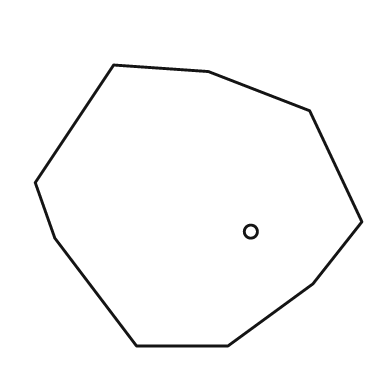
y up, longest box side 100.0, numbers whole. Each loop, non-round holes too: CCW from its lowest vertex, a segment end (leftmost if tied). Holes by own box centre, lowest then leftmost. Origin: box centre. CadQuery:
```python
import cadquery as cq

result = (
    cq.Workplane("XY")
    .moveTo(-19.0, -43.0)
    .lineTo(9.0, -43.0)
    .lineTo(35.0, -24.0)
    .lineTo(50.0, -5.0)
    .lineTo(34.0, 29.0)
    .lineTo(3.0, 41.0)
    .lineTo(-26.0, 43.0)
    .lineTo(-50.0, 7.0)
    .lineTo(-44.0, -10.0)
    .close()
    .moveTo(16.0, -8.0)
    .circle(2.0)
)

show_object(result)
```